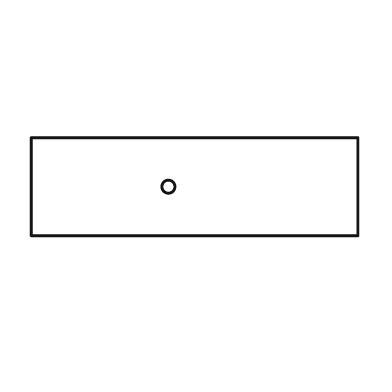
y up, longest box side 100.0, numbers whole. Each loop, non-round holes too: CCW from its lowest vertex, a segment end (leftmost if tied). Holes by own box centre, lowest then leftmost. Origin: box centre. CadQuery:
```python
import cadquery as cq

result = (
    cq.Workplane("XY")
    .moveTo(-50.0, -15.0)
    .lineTo(50.0, -15.0)
    .lineTo(50.0, 15.0)
    .lineTo(-50.0, 15.0)
    .close()
    .moveTo(-8.0, 0.0)
    .circle(2.0)
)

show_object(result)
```